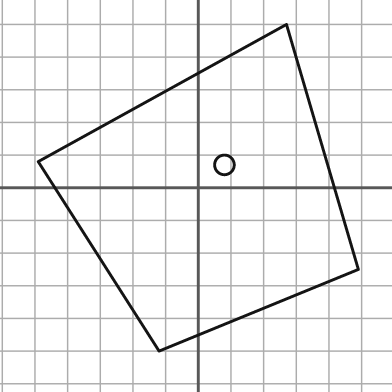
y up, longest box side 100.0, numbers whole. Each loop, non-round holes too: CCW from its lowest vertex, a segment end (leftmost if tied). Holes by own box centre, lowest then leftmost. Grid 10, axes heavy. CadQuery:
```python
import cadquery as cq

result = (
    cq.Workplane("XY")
    .moveTo(-12.0, -50.0)
    .lineTo(49.0, -25.0)
    .lineTo(27.0, 50.0)
    .lineTo(-49.0, 8.0)
    .close()
    .moveTo(8.0, 7.0)
    .circle(3.0)
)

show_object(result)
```